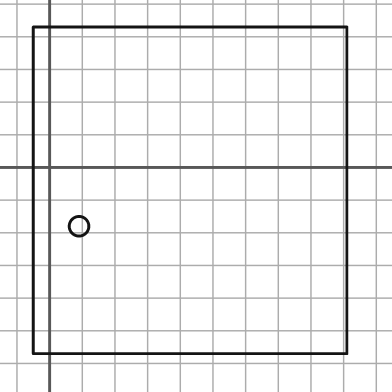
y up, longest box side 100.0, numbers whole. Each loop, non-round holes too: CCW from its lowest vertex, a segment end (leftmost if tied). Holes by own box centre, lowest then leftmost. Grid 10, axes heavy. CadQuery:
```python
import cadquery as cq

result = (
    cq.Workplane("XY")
    .moveTo(-5.0, -57.0)
    .lineTo(91.0, -57.0)
    .lineTo(91.0, 43.0)
    .lineTo(-5.0, 43.0)
    .close()
    .moveTo(9.0, -18.0)
    .circle(3.0)
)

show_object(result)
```